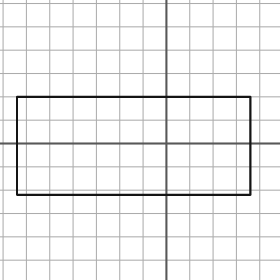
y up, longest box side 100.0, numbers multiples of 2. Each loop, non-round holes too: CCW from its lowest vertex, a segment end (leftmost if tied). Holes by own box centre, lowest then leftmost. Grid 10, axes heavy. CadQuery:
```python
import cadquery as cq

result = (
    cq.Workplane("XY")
    .moveTo(-64.0, -22.0)
    .lineTo(36.0, -22.0)
    .lineTo(36.0, 20.0)
    .lineTo(-64.0, 20.0)
    .close()
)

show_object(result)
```